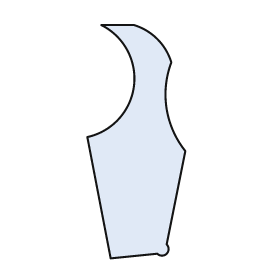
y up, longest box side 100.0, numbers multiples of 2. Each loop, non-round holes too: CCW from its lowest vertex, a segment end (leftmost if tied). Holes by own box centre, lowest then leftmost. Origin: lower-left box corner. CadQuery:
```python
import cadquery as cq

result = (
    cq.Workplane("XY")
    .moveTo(10.0, 0.0)
    .lineTo(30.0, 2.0)
    .threePointArc((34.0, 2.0), (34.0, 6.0))
    .lineTo(42.0, 46.0)
    .threePointArc((34.0, 64.0), (36.0, 84.0))
    .threePointArc((30.0, 94.0), (20.0, 100.0))
    .lineTo(6.0, 100.0)
    .threePointArc((20.0, 74.0), (0.0, 52.0))
    .close()
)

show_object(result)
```